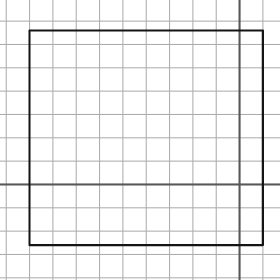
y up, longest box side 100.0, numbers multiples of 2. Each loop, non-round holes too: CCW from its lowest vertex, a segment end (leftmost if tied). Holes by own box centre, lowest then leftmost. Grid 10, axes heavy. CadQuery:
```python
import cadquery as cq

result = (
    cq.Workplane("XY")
    .moveTo(-90.0, -26.0)
    .lineTo(10.0, -26.0)
    .lineTo(10.0, 66.0)
    .lineTo(-90.0, 66.0)
    .close()
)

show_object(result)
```